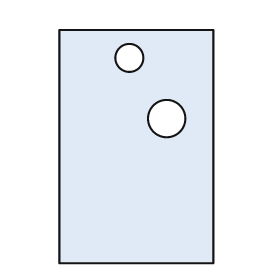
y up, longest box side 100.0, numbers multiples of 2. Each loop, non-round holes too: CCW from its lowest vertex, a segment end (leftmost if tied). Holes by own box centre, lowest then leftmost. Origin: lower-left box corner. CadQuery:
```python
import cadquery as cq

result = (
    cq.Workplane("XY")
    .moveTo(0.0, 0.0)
    .lineTo(66.0, 0.0)
    .lineTo(66.0, 100.0)
    .lineTo(0.0, 100.0)
    .close()
    .moveTo(46.0, 62.0)
    .circle(8.0)
    .moveTo(30.0, 88.0)
    .circle(6.0)
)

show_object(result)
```